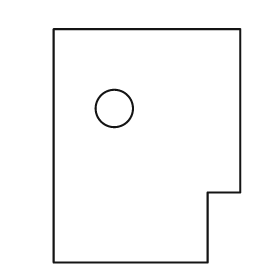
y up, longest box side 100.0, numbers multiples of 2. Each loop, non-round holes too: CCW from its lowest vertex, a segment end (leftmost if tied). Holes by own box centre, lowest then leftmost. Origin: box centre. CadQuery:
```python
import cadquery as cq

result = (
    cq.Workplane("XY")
    .moveTo(-40.0, -50.0)
    .lineTo(26.0, -50.0)
    .lineTo(26.0, -20.0)
    .lineTo(40.0, -20.0)
    .lineTo(40.0, 50.0)
    .lineTo(-40.0, 50.0)
    .close()
    .moveTo(-14.0, 16.0)
    .circle(8.0)
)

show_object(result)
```